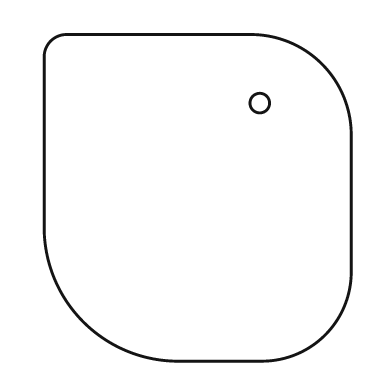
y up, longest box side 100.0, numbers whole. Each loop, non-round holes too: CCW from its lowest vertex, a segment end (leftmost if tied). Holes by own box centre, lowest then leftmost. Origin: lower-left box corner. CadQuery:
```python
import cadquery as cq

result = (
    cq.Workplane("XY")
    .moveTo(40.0, 0.0)
    .lineTo(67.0, 0.0)
    .threePointArc((86.0, 8.0), (94.0, 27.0))
    .lineTo(94.0, 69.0)
    .threePointArc((85.0, 91.0), (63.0, 100.0))
    .lineTo(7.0, 100.0)
    .threePointArc((2.0, 98.0), (0.0, 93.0))
    .lineTo(0.0, 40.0)
    .threePointArc((12.0, 12.0), (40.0, 0.0))
    .close()
    .moveTo(66.0, 79.0)
    .circle(3.0)
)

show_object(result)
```